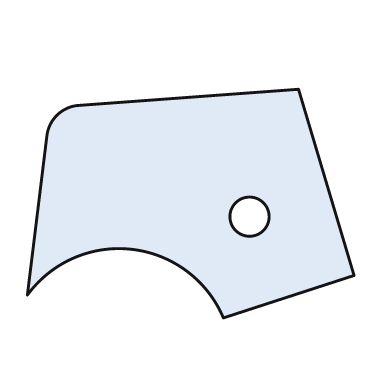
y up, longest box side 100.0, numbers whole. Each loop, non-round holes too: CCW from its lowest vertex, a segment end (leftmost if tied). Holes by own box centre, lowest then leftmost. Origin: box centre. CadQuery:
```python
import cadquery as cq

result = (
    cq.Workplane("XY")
    .moveTo(10.0, -35.0)
    .lineTo(50.0, -22.0)
    .lineTo(33.0, 35.0)
    .lineTo(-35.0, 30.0)
    .threePointArc((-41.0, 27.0), (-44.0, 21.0))
    .lineTo(-50.0, -28.0)
    .threePointArc((-18.0, -14.0), (10.0, -35.0))
    .close()
    .moveTo(18.0, -4.0)
    .circle(6.0)
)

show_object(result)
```